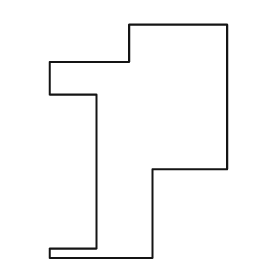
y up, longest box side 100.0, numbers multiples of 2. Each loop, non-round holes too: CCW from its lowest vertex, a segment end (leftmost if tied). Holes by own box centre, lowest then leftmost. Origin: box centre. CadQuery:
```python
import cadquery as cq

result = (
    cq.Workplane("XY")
    .moveTo(-38.0, -50.0)
    .lineTo(6.0, -50.0)
    .lineTo(6.0, -12.0)
    .lineTo(38.0, -12.0)
    .lineTo(38.0, 50.0)
    .lineTo(-4.0, 50.0)
    .lineTo(-4.0, 34.0)
    .lineTo(-38.0, 34.0)
    .lineTo(-38.0, 20.0)
    .lineTo(-18.0, 20.0)
    .lineTo(-18.0, -46.0)
    .lineTo(-38.0, -46.0)
    .close()
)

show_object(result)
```